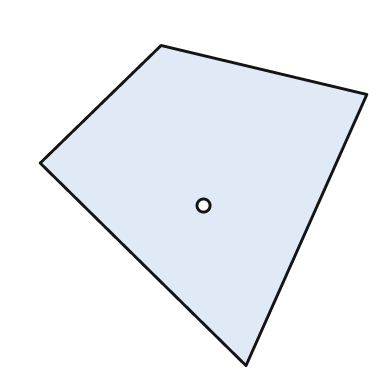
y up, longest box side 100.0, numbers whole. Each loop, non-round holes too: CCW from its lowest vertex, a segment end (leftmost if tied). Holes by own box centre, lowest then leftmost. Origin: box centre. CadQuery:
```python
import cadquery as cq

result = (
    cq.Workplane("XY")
    .moveTo(13.0, -49.0)
    .lineTo(50.0, 34.0)
    .lineTo(-13.0, 49.0)
    .lineTo(-50.0, 13.0)
    .close()
    .moveTo(0.0, 0.0)
    .circle(2.0)
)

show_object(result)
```